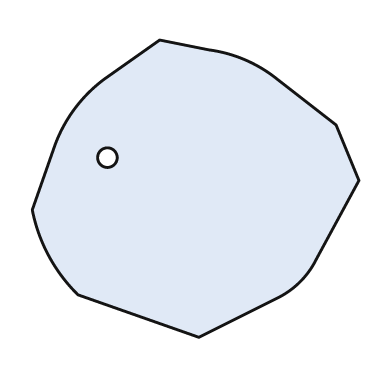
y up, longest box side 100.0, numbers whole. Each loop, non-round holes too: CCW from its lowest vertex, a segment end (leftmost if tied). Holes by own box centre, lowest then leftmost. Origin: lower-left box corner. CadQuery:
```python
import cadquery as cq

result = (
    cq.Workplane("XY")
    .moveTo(51.0, 0.0)
    .lineTo(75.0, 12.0)
    .threePointArc((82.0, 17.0), (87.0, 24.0))
    .lineTo(100.0, 48.0)
    .lineTo(93.0, 65.0)
    .lineTo(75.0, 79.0)
    .threePointArc((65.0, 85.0), (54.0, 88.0))
    .lineTo(39.0, 91.0)
    .lineTo(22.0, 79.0)
    .threePointArc((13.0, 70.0), (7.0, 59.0))
    .lineTo(0.0, 39.0)
    .threePointArc((5.0, 25.0), (14.0, 13.0))
    .close()
    .moveTo(23.0, 55.0)
    .circle(3.0)
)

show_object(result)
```